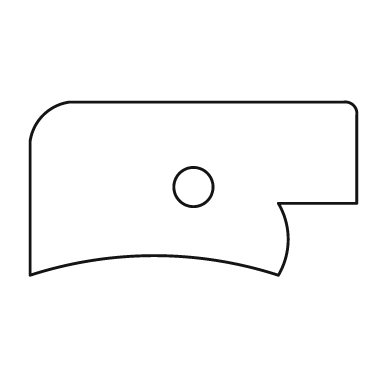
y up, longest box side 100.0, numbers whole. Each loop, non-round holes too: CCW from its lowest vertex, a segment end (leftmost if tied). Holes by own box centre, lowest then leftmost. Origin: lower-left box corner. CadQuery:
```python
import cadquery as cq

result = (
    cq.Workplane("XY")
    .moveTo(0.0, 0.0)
    .threePointArc((38.0, 6.0), (76.0, 0.0))
    .threePointArc((79.0, 11.0), (76.0, 22.0))
    .lineTo(100.0, 22.0)
    .lineTo(100.0, 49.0)
    .threePointArc((99.0, 52.0), (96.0, 53.0))
    .lineTo(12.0, 53.0)
    .threePointArc((4.0, 49.0), (0.0, 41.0))
    .close()
    .moveTo(50.0, 27.0)
    .circle(6.0)
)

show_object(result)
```